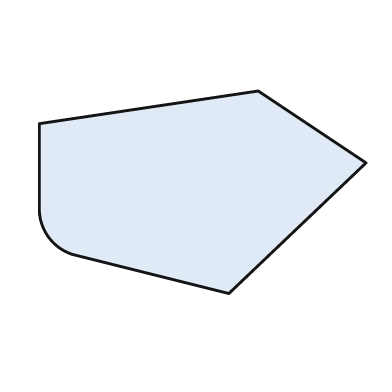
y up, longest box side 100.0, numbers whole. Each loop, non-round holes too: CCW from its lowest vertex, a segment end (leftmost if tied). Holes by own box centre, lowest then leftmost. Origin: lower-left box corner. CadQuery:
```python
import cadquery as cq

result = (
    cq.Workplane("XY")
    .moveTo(58.0, 0.0)
    .lineTo(100.0, 40.0)
    .lineTo(67.0, 62.0)
    .lineTo(0.0, 52.0)
    .lineTo(0.0, 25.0)
    .threePointArc((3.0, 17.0), (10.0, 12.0))
    .close()
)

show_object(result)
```